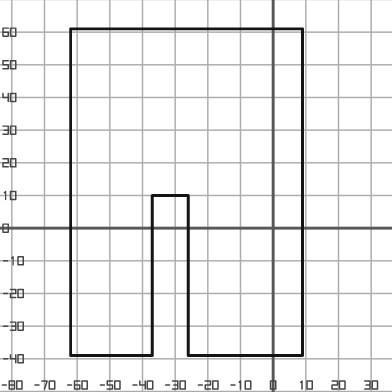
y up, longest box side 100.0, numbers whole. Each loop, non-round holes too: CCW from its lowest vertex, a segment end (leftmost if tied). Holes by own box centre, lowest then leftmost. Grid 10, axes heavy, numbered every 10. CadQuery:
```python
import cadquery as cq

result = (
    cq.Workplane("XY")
    .moveTo(-62.0, -39.0)
    .lineTo(-37.0, -39.0)
    .lineTo(-37.0, 10.0)
    .lineTo(-26.0, 10.0)
    .lineTo(-26.0, -39.0)
    .lineTo(9.0, -39.0)
    .lineTo(9.0, 61.0)
    .lineTo(-62.0, 61.0)
    .close()
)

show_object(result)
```